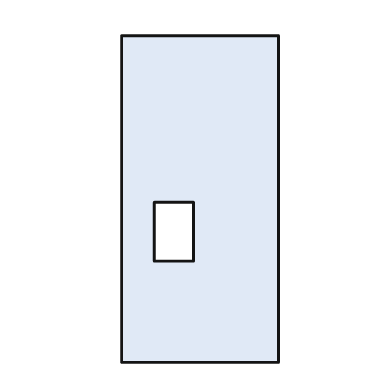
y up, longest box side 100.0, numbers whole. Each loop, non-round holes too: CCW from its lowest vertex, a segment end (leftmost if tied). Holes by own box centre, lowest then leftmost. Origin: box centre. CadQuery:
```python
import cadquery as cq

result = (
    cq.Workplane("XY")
    .moveTo(-24.0, -50.0)
    .lineTo(24.0, -50.0)
    .lineTo(24.0, 50.0)
    .lineTo(-24.0, 50.0)
    .close()
    .moveTo(-14.0, -19.0)
    .lineTo(-2.0, -19.0)
    .lineTo(-2.0, -1.0)
    .lineTo(-14.0, -1.0)
    .close()
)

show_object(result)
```